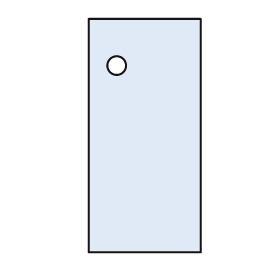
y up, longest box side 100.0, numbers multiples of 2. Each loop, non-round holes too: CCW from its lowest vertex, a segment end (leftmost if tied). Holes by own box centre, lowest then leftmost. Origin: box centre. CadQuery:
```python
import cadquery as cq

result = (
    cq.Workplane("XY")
    .moveTo(-24.0, -50.0)
    .lineTo(24.0, -50.0)
    .lineTo(24.0, 50.0)
    .lineTo(-24.0, 50.0)
    .close()
    .moveTo(-12.0, 30.0)
    .circle(4.0)
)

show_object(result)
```